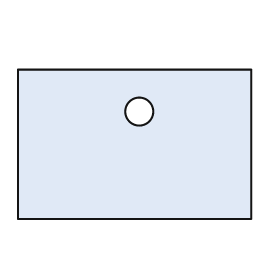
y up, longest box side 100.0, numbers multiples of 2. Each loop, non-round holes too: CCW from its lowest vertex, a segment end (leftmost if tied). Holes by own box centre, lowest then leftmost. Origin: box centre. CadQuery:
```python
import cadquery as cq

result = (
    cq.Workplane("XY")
    .moveTo(-50.0, -32.0)
    .lineTo(50.0, -32.0)
    .lineTo(50.0, 32.0)
    .lineTo(-50.0, 32.0)
    .close()
    .moveTo(2.0, 14.0)
    .circle(6.0)
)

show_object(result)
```